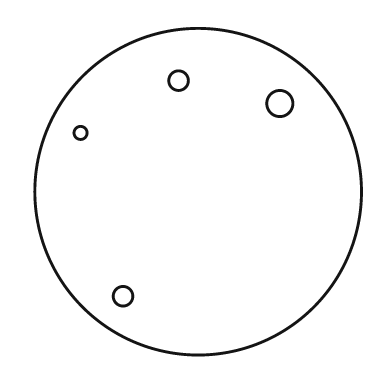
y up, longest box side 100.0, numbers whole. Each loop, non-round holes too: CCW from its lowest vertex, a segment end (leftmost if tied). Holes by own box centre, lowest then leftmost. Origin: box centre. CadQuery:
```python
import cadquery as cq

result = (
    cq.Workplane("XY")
    .moveTo(0.0, 0.0)
    .circle(50.0)
    .moveTo(-23.0, -32.0)
    .circle(3.0)
    .moveTo(-36.0, 18.0)
    .circle(2.0)
    .moveTo(25.0, 27.0)
    .circle(4.0)
    .moveTo(-6.0, 34.0)
    .circle(3.0)
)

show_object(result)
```